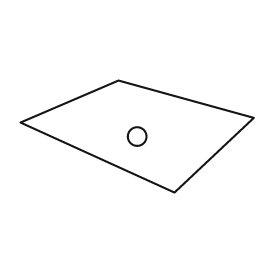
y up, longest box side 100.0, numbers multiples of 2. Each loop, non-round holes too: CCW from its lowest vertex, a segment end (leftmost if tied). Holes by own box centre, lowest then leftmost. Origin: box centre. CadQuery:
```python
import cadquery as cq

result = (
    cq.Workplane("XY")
    .moveTo(16.0, -24.0)
    .lineTo(50.0, 8.0)
    .lineTo(-8.0, 24.0)
    .lineTo(-50.0, 6.0)
    .close()
    .moveTo(0.0, 0.0)
    .circle(4.0)
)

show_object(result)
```